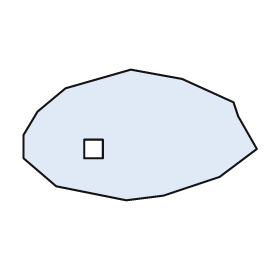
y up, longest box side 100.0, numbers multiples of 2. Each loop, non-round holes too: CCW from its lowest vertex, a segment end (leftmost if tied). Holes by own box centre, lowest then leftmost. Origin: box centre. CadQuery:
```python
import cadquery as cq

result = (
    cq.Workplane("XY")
    .moveTo(-6.0, -28.0)
    .lineTo(10.0, -26.0)
    .lineTo(34.0, -18.0)
    .lineTo(50.0, -6.0)
    .lineTo(42.0, 8.0)
    .lineTo(40.0, 14.0)
    .lineTo(18.0, 24.0)
    .lineTo(-4.0, 28.0)
    .lineTo(-32.0, 20.0)
    .lineTo(-44.0, 10.0)
    .lineTo(-50.0, 0.0)
    .lineTo(-50.0, -10.0)
    .lineTo(-36.0, -22.0)
    .close()
    .moveTo(-24.0, -10.0)
    .lineTo(-16.0, -10.0)
    .lineTo(-16.0, -2.0)
    .lineTo(-24.0, -2.0)
    .close()
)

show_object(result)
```